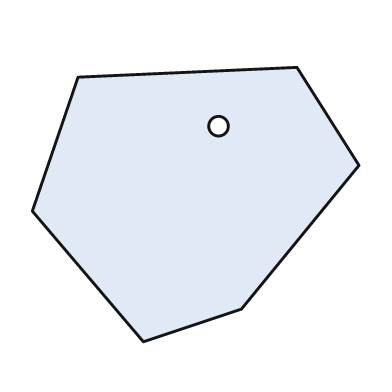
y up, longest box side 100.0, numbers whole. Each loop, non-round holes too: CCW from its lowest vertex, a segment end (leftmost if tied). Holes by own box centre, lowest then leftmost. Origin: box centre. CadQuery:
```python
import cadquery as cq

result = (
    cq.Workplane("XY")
    .moveTo(-16.0, -42.0)
    .lineTo(14.0, -32.0)
    .lineTo(50.0, 12.0)
    .lineTo(31.0, 42.0)
    .lineTo(-36.0, 39.0)
    .lineTo(-50.0, -2.0)
    .close()
    .moveTo(7.0, 24.0)
    .circle(3.0)
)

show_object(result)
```